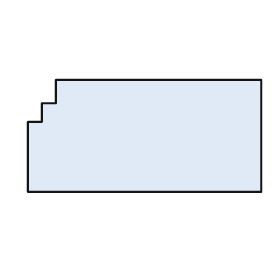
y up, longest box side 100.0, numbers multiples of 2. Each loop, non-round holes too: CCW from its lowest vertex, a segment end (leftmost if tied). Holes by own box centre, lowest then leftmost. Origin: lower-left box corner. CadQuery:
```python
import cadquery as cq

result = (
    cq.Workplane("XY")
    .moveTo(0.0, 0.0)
    .lineTo(100.0, 0.0)
    .lineTo(100.0, 48.0)
    .lineTo(12.0, 48.0)
    .lineTo(12.0, 38.0)
    .lineTo(6.0, 38.0)
    .lineTo(6.0, 30.0)
    .lineTo(0.0, 30.0)
    .close()
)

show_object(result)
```